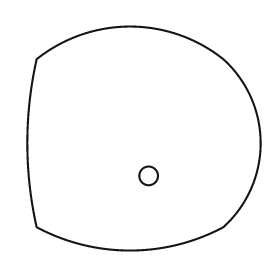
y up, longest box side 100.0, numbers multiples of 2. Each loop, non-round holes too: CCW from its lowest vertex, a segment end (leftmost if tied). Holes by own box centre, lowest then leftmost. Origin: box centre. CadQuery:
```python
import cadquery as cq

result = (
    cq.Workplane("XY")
    .moveTo(-46.0, -38.0)
    .threePointArc((-6.0, -48.0), (34.0, -38.0))
    .threePointArc((50.0, -2.0), (34.0, 34.0))
    .threePointArc((-6.0, 48.0), (-46.0, 34.0))
    .threePointArc((-50.0, -2.0), (-46.0, -38.0))
    .close()
    .moveTo(2.0, -16.0)
    .circle(4.0)
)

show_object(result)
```